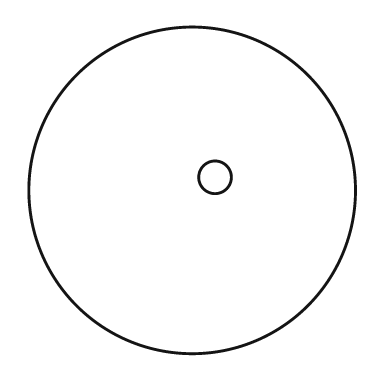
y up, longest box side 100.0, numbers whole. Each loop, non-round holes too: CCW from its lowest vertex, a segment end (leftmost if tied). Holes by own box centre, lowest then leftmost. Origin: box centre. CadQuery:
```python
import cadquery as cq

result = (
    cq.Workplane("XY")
    .moveTo(0.0, 0.0)
    .circle(50.0)
    .moveTo(7.0, 4.0)
    .circle(5.0)
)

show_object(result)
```